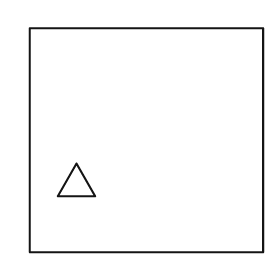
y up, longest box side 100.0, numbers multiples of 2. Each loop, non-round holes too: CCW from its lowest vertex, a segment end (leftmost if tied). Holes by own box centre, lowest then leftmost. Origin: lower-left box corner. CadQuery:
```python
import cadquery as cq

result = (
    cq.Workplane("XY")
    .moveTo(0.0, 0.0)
    .lineTo(100.0, 0.0)
    .lineTo(100.0, 96.0)
    .lineTo(0.0, 96.0)
    .close()
    .moveTo(12.0, 24.0)
    .lineTo(28.0, 24.0)
    .lineTo(20.0, 38.0)
    .close()
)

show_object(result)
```